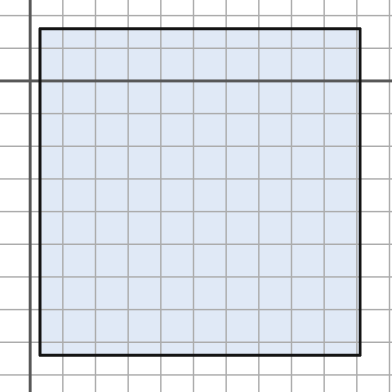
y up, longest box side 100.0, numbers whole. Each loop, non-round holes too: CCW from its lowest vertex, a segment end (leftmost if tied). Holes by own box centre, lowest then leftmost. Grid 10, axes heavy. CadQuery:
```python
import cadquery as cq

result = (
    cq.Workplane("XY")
    .moveTo(3.0, -84.0)
    .lineTo(101.0, -84.0)
    .lineTo(101.0, 16.0)
    .lineTo(3.0, 16.0)
    .close()
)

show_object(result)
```